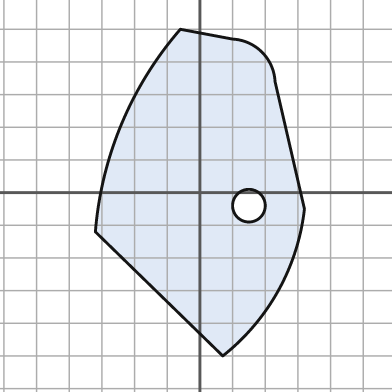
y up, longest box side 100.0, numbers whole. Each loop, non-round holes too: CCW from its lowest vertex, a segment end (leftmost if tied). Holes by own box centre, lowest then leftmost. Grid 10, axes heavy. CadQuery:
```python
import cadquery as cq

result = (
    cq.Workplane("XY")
    .moveTo(7.0, -50.0)
    .threePointArc((24.0, -30.0), (32.0, -5.0))
    .lineTo(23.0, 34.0)
    .threePointArc((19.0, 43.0), (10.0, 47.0))
    .lineTo(-6.0, 50.0)
    .threePointArc((-24.0, 21.0), (-32.0, -12.0))
    .close()
    .moveTo(15.0, -4.0)
    .circle(5.0)
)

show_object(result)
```